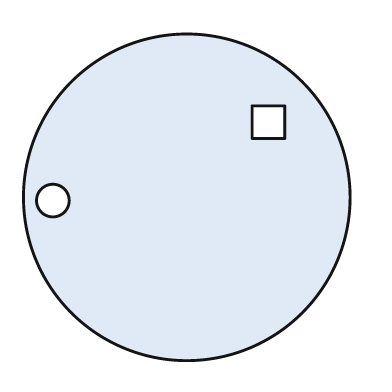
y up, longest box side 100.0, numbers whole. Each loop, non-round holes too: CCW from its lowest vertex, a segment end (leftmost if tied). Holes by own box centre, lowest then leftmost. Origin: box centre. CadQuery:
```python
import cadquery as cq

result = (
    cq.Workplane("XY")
    .moveTo(0.0, 0.0)
    .circle(50.0)
    .moveTo(-41.0, -1.0)
    .circle(5.0)
    .moveTo(20.0, 18.0)
    .lineTo(30.0, 18.0)
    .lineTo(30.0, 28.0)
    .lineTo(20.0, 28.0)
    .close()
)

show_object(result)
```